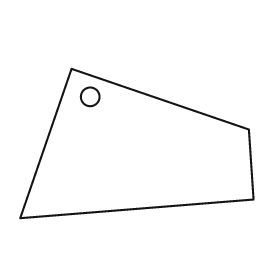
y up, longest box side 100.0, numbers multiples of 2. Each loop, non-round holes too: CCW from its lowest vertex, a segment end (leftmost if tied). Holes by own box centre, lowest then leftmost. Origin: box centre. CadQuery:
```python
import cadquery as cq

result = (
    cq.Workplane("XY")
    .moveTo(-50.0, -32.0)
    .lineTo(50.0, -24.0)
    .lineTo(48.0, 6.0)
    .lineTo(-28.0, 32.0)
    .close()
    .moveTo(-20.0, 20.0)
    .circle(4.0)
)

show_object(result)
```